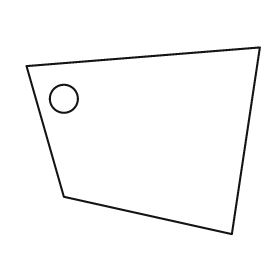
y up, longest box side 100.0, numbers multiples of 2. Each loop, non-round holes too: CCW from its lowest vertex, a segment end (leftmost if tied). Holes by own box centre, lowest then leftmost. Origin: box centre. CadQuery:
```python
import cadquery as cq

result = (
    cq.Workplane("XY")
    .moveTo(38.0, -40.0)
    .lineTo(50.0, 40.0)
    .lineTo(-50.0, 32.0)
    .lineTo(-34.0, -24.0)
    .close()
    .moveTo(-34.0, 18.0)
    .circle(6.0)
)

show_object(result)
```